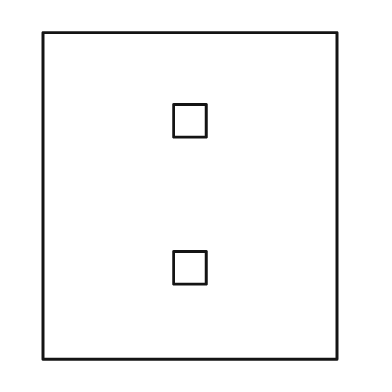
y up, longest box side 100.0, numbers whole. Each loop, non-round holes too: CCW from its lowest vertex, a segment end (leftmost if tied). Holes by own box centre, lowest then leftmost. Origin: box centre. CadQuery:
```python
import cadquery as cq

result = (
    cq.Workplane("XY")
    .moveTo(-45.0, -50.0)
    .lineTo(45.0, -50.0)
    .lineTo(45.0, 50.0)
    .lineTo(-45.0, 50.0)
    .close()
    .moveTo(-5.0, -27.0)
    .lineTo(5.0, -27.0)
    .lineTo(5.0, -17.0)
    .lineTo(-5.0, -17.0)
    .close()
    .moveTo(-5.0, 18.0)
    .lineTo(5.0, 18.0)
    .lineTo(5.0, 28.0)
    .lineTo(-5.0, 28.0)
    .close()
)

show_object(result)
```